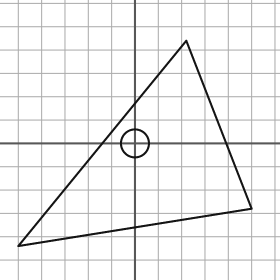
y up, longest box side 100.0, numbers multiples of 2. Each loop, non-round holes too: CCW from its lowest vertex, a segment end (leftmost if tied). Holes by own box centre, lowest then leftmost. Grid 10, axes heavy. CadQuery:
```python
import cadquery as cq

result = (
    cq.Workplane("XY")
    .moveTo(-50.0, -44.0)
    .lineTo(50.0, -28.0)
    .lineTo(22.0, 44.0)
    .close()
    .moveTo(0.0, 0.0)
    .circle(6.0)
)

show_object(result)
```